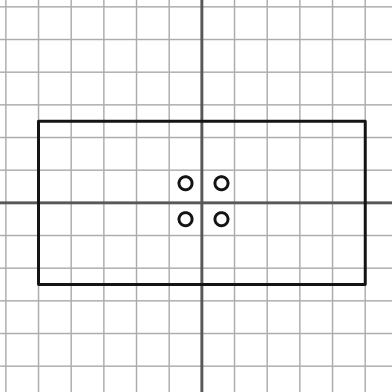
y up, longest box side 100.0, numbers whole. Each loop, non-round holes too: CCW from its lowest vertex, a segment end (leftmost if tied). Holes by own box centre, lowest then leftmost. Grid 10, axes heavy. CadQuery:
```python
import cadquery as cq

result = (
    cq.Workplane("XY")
    .moveTo(-50.0, -25.0)
    .lineTo(50.0, -25.0)
    .lineTo(50.0, 25.0)
    .lineTo(-50.0, 25.0)
    .close()
    .moveTo(-5.0, -5.0)
    .circle(2.0)
    .moveTo(6.0, -5.0)
    .circle(2.0)
    .moveTo(-5.0, 6.0)
    .circle(2.0)
    .moveTo(6.0, 6.0)
    .circle(2.0)
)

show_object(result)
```